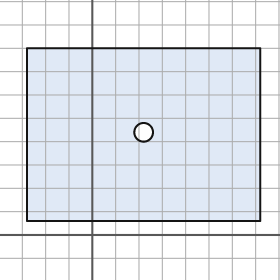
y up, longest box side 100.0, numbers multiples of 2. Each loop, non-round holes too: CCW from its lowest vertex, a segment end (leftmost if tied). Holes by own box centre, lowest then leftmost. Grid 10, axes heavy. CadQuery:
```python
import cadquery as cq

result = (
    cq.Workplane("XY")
    .moveTo(-28.0, 6.0)
    .lineTo(72.0, 6.0)
    .lineTo(72.0, 80.0)
    .lineTo(-28.0, 80.0)
    .close()
    .moveTo(22.0, 44.0)
    .circle(4.0)
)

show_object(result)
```